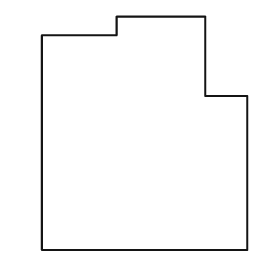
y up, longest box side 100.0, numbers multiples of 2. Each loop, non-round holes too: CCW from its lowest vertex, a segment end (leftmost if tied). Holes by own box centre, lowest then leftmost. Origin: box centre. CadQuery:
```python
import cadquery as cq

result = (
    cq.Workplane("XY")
    .moveTo(-44.0, -50.0)
    .lineTo(44.0, -50.0)
    .lineTo(44.0, 16.0)
    .lineTo(26.0, 16.0)
    .lineTo(26.0, 50.0)
    .lineTo(-12.0, 50.0)
    .lineTo(-12.0, 42.0)
    .lineTo(-44.0, 42.0)
    .close()
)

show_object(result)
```